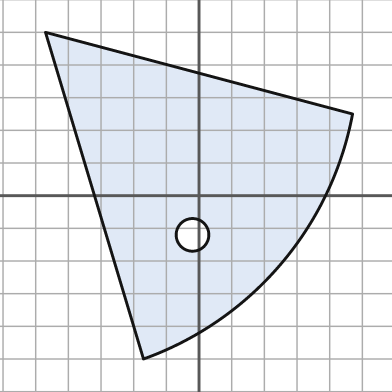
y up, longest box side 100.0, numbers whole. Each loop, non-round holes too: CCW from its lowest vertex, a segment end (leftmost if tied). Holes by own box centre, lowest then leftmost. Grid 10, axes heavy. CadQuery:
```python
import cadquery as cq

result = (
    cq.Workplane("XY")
    .moveTo(-17.0, -50.0)
    .threePointArc((25.0, -21.0), (47.0, 25.0))
    .lineTo(-47.0, 50.0)
    .close()
    .moveTo(-2.0, -12.0)
    .circle(5.0)
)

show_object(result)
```